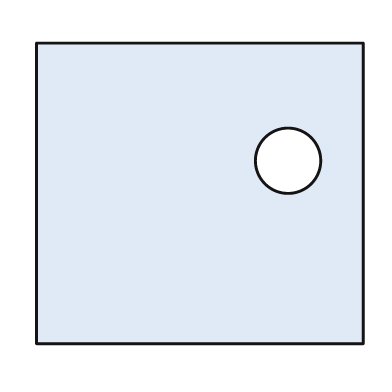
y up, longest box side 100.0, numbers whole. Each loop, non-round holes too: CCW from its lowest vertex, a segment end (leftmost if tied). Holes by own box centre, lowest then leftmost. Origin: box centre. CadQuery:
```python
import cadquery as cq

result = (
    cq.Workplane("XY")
    .moveTo(-50.0, -46.0)
    .lineTo(50.0, -46.0)
    .lineTo(50.0, 46.0)
    .lineTo(-50.0, 46.0)
    .close()
    .moveTo(27.0, 10.0)
    .circle(10.0)
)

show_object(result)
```